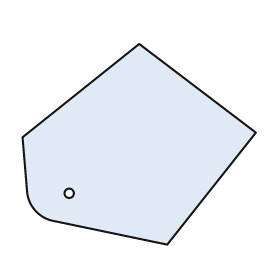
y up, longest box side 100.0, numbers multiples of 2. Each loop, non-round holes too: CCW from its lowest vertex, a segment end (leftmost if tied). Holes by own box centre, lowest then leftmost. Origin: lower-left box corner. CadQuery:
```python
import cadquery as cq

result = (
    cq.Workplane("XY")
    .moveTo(62.0, 0.0)
    .lineTo(100.0, 48.0)
    .lineTo(50.0, 86.0)
    .lineTo(0.0, 46.0)
    .lineTo(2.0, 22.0)
    .threePointArc((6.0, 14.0), (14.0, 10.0))
    .close()
    .moveTo(20.0, 22.0)
    .circle(2.0)
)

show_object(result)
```